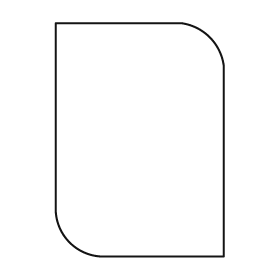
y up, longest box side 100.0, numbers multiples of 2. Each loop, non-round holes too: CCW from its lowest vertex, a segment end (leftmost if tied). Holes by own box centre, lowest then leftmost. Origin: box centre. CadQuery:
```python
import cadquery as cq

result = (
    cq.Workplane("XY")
    .moveTo(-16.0, -50.0)
    .lineTo(36.0, -50.0)
    .lineTo(36.0, 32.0)
    .threePointArc((30.0, 44.0), (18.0, 50.0))
    .lineTo(-36.0, 50.0)
    .lineTo(-36.0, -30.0)
    .threePointArc((-30.0, -44.0), (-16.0, -50.0))
    .close()
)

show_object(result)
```